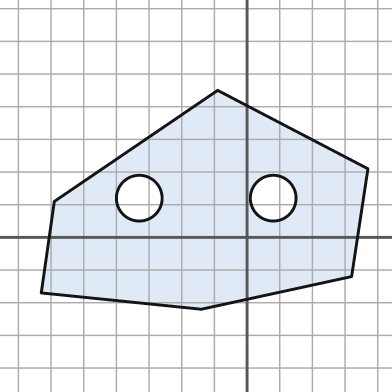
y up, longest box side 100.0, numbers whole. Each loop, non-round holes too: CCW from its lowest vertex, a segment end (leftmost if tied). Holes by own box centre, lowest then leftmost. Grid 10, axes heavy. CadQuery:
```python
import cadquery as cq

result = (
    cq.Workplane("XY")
    .moveTo(-14.0, -22.0)
    .lineTo(32.0, -12.0)
    .lineTo(37.0, 21.0)
    .lineTo(-9.0, 45.0)
    .lineTo(-59.0, 11.0)
    .lineTo(-63.0, -17.0)
    .close()
    .moveTo(-33.0, 12.0)
    .circle(7.0)
    .moveTo(8.0, 12.0)
    .circle(7.0)
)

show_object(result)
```